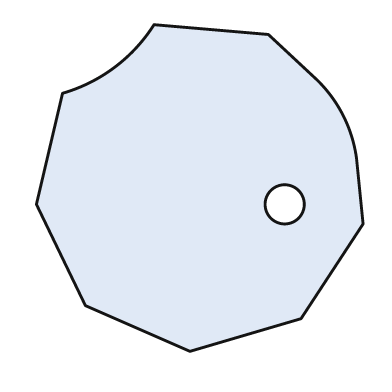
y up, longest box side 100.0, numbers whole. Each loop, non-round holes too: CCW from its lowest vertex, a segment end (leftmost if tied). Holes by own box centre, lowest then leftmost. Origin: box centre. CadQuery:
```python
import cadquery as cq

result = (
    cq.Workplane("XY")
    .moveTo(-3.0, -50.0)
    .lineTo(31.0, -40.0)
    .lineTo(50.0, -11.0)
    .lineTo(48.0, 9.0)
    .threePointArc((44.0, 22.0), (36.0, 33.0))
    .lineTo(21.0, 47.0)
    .lineTo(-14.0, 50.0)
    .threePointArc((-26.0, 37.0), (-42.0, 29.0))
    .lineTo(-50.0, -5.0)
    .lineTo(-35.0, -36.0)
    .close()
    .moveTo(26.0, -5.0)
    .circle(6.0)
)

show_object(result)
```